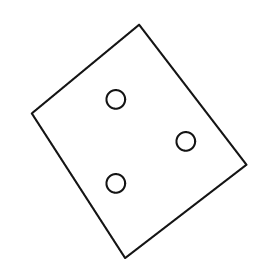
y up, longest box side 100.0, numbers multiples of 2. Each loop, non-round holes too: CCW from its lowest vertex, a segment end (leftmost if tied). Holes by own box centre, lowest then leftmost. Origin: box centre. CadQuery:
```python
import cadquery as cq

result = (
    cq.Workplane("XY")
    .moveTo(-6.0, -50.0)
    .lineTo(46.0, -10.0)
    .lineTo(0.0, 50.0)
    .lineTo(-46.0, 12.0)
    .close()
    .moveTo(-10.0, -18.0)
    .circle(4.0)
    .moveTo(20.0, 0.0)
    .circle(4.0)
    .moveTo(-10.0, 18.0)
    .circle(4.0)
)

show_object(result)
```